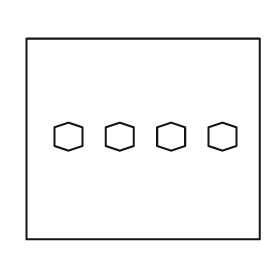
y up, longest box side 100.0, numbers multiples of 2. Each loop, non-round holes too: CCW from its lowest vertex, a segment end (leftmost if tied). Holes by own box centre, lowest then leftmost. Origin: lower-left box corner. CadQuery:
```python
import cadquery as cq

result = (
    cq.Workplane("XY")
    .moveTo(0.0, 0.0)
    .lineTo(100.0, 0.0)
    .lineTo(100.0, 86.0)
    .lineTo(0.0, 86.0)
    .close()
    .moveTo(18.0, 38.0)
    .lineTo(24.0, 40.0)
    .lineTo(24.0, 48.0)
    .lineTo(18.0, 50.0)
    .lineTo(12.0, 48.0)
    .lineTo(12.0, 40.0)
    .close()
    .moveTo(40.0, 38.0)
    .lineTo(46.0, 40.0)
    .lineTo(46.0, 48.0)
    .lineTo(40.0, 50.0)
    .lineTo(34.0, 48.0)
    .lineTo(34.0, 40.0)
    .close()
    .moveTo(62.0, 38.0)
    .lineTo(68.0, 40.0)
    .lineTo(68.0, 48.0)
    .lineTo(62.0, 50.0)
    .lineTo(56.0, 48.0)
    .lineTo(56.0, 40.0)
    .close()
    .moveTo(84.0, 38.0)
    .lineTo(90.0, 40.0)
    .lineTo(90.0, 48.0)
    .lineTo(84.0, 50.0)
    .lineTo(78.0, 48.0)
    .lineTo(78.0, 40.0)
    .close()
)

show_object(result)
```